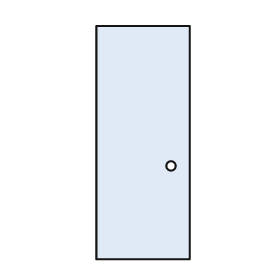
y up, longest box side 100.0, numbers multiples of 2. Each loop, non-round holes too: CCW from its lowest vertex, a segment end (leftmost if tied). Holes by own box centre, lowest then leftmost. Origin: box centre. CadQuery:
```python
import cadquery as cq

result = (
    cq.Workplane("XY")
    .moveTo(-20.0, -50.0)
    .lineTo(20.0, -50.0)
    .lineTo(20.0, 50.0)
    .lineTo(-20.0, 50.0)
    .close()
    .moveTo(12.0, -10.0)
    .circle(2.0)
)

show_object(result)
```